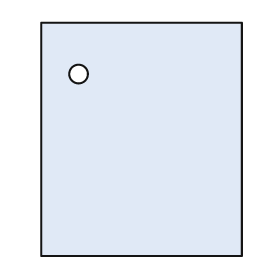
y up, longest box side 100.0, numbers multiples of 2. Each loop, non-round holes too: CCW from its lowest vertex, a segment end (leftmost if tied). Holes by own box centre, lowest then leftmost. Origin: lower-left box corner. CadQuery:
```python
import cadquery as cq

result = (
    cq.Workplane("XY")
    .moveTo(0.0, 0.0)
    .lineTo(86.0, 0.0)
    .lineTo(86.0, 100.0)
    .lineTo(0.0, 100.0)
    .close()
    .moveTo(16.0, 78.0)
    .circle(4.0)
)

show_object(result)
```